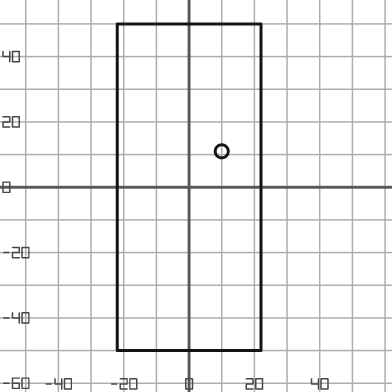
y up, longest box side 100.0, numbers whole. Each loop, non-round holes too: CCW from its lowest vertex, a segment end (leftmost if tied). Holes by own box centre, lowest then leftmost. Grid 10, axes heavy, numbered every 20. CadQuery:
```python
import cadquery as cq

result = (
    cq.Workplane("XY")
    .moveTo(-22.0, -50.0)
    .lineTo(22.0, -50.0)
    .lineTo(22.0, 50.0)
    .lineTo(-22.0, 50.0)
    .close()
    .moveTo(10.0, 11.0)
    .circle(2.0)
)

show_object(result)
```